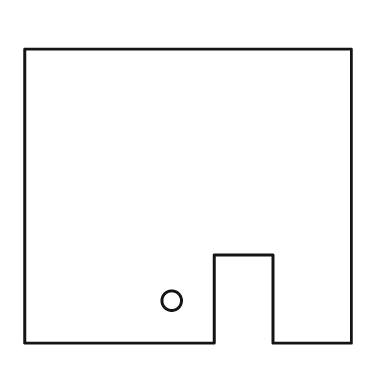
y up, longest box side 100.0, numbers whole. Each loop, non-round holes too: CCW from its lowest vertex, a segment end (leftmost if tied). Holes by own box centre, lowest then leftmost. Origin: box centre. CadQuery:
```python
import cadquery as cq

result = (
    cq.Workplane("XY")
    .moveTo(-50.0, -45.0)
    .lineTo(8.0, -45.0)
    .lineTo(8.0, -18.0)
    .lineTo(26.0, -18.0)
    .lineTo(26.0, -45.0)
    .lineTo(50.0, -45.0)
    .lineTo(50.0, 45.0)
    .lineTo(-50.0, 45.0)
    .close()
    .moveTo(-5.0, -32.0)
    .circle(3.0)
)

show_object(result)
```